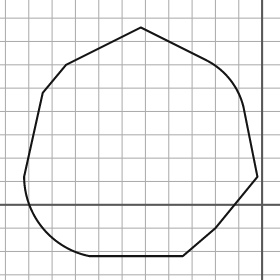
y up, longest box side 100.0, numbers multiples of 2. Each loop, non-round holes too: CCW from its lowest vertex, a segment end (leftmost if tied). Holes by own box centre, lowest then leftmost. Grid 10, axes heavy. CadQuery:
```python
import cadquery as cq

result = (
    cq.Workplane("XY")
    .moveTo(-74.0, -22.0)
    .lineTo(-34.0, -22.0)
    .lineTo(-20.0, -10.0)
    .lineTo(-2.0, 12.0)
    .lineTo(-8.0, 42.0)
    .threePointArc((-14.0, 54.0), (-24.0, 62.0))
    .lineTo(-52.0, 76.0)
    .lineTo(-84.0, 60.0)
    .lineTo(-94.0, 48.0)
    .lineTo(-102.0, 12.0)
    .threePointArc((-94.0, -10.0), (-74.0, -22.0))
    .close()
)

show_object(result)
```